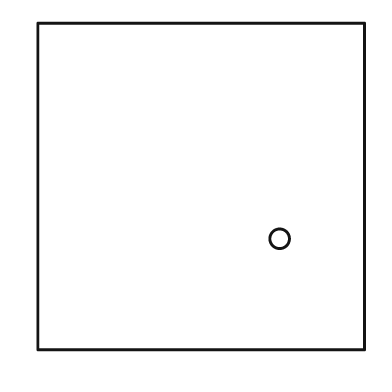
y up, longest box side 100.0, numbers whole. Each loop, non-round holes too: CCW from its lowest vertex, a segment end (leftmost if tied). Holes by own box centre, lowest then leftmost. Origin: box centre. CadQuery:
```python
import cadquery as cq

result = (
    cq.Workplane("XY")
    .moveTo(-50.0, -50.0)
    .lineTo(50.0, -50.0)
    .lineTo(50.0, 50.0)
    .lineTo(-50.0, 50.0)
    .close()
    .moveTo(24.0, -16.0)
    .circle(3.0)
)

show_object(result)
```